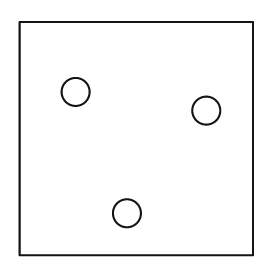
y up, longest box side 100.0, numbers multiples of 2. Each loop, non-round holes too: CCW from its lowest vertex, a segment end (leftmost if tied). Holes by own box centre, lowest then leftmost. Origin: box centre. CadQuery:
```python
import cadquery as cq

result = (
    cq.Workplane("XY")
    .moveTo(-50.0, -50.0)
    .lineTo(50.0, -50.0)
    .lineTo(50.0, 50.0)
    .lineTo(-50.0, 50.0)
    .close()
    .moveTo(-4.0, -32.0)
    .circle(6.0)
    .moveTo(30.0, 12.0)
    .circle(6.0)
    .moveTo(-26.0, 20.0)
    .circle(6.0)
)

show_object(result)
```